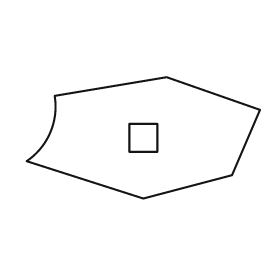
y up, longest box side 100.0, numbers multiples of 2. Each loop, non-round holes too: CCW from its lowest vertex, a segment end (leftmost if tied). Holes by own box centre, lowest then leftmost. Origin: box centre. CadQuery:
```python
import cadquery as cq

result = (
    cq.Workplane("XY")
    .moveTo(0.0, -26.0)
    .lineTo(38.0, -16.0)
    .lineTo(50.0, 12.0)
    .lineTo(10.0, 26.0)
    .lineTo(-38.0, 18.0)
    .threePointArc((-40.0, 2.0), (-50.0, -10.0))
    .close()
    .moveTo(-6.0, -6.0)
    .lineTo(6.0, -6.0)
    .lineTo(6.0, 6.0)
    .lineTo(-6.0, 6.0)
    .close()
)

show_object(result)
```